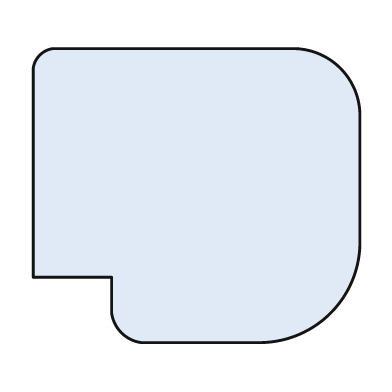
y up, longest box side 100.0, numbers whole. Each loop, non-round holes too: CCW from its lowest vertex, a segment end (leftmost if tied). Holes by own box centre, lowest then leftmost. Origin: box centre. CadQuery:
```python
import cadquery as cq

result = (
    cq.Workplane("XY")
    .moveTo(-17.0, -45.0)
    .lineTo(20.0, -45.0)
    .threePointArc((41.0, -36.0), (50.0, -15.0))
    .lineTo(50.0, 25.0)
    .threePointArc((44.0, 39.0), (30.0, 45.0))
    .lineTo(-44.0, 45.0)
    .threePointArc((-48.0, 43.0), (-50.0, 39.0))
    .lineTo(-50.0, -25.0)
    .lineTo(-26.0, -25.0)
    .lineTo(-26.0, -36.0)
    .threePointArc((-23.0, -42.0), (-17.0, -45.0))
    .close()
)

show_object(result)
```